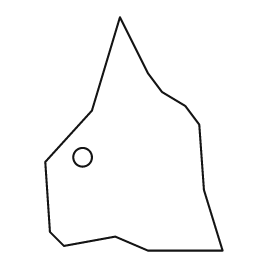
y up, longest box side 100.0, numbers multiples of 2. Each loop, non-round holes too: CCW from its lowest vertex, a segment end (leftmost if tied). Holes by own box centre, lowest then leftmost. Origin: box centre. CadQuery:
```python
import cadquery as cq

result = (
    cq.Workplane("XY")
    .moveTo(6.0, -50.0)
    .lineTo(38.0, -50.0)
    .lineTo(30.0, -24.0)
    .lineTo(28.0, 4.0)
    .lineTo(22.0, 12.0)
    .lineTo(12.0, 18.0)
    .lineTo(6.0, 26.0)
    .lineTo(-6.0, 50.0)
    .lineTo(-18.0, 10.0)
    .lineTo(-38.0, -12.0)
    .lineTo(-36.0, -42.0)
    .lineTo(-30.0, -48.0)
    .lineTo(-8.0, -44.0)
    .close()
    .moveTo(-22.0, -10.0)
    .circle(4.0)
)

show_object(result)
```